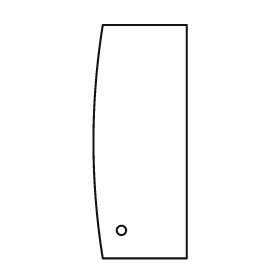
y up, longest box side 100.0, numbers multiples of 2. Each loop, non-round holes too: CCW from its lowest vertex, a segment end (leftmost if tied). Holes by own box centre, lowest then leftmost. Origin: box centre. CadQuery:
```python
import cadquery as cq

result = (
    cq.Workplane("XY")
    .moveTo(-16.0, -50.0)
    .lineTo(20.0, -50.0)
    .lineTo(20.0, 50.0)
    .lineTo(-16.0, 50.0)
    .threePointArc((-20.0, 0.0), (-16.0, -50.0))
    .close()
    .moveTo(-8.0, -38.0)
    .circle(2.0)
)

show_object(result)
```